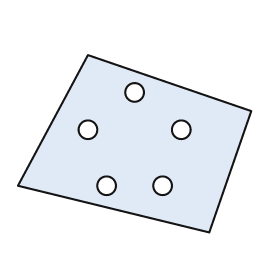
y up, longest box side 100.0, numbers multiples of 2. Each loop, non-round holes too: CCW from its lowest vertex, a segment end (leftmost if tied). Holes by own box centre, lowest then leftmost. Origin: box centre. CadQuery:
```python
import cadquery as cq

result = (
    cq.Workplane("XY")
    .moveTo(32.0, -38.0)
    .lineTo(50.0, 14.0)
    .lineTo(-20.0, 38.0)
    .lineTo(-50.0, -18.0)
    .close()
    .moveTo(-12.0, -18.0)
    .circle(4.0)
    .moveTo(12.0, -18.0)
    .circle(4.0)
    .moveTo(-20.0, 6.0)
    .circle(4.0)
    .moveTo(20.0, 6.0)
    .circle(4.0)
    .moveTo(0.0, 22.0)
    .circle(4.0)
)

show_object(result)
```